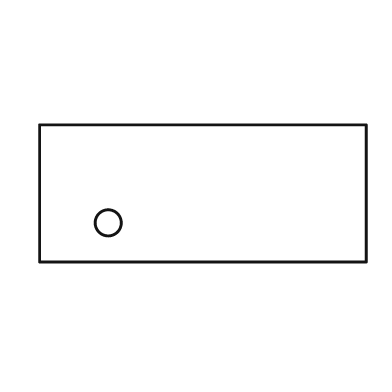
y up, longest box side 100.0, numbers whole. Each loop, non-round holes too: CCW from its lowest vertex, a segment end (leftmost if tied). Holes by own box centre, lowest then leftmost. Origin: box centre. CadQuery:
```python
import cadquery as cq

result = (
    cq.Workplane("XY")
    .moveTo(-50.0, -21.0)
    .lineTo(50.0, -21.0)
    .lineTo(50.0, 21.0)
    .lineTo(-50.0, 21.0)
    .close()
    .moveTo(-29.0, -9.0)
    .circle(4.0)
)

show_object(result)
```